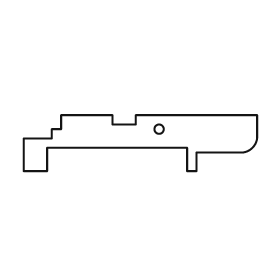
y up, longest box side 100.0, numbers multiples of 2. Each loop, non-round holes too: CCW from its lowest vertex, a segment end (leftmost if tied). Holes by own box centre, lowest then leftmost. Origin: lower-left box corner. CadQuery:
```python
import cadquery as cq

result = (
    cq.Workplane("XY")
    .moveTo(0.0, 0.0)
    .lineTo(10.0, 0.0)
    .lineTo(10.0, 10.0)
    .lineTo(70.0, 10.0)
    .lineTo(70.0, 0.0)
    .lineTo(74.0, 0.0)
    .lineTo(74.0, 8.0)
    .lineTo(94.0, 8.0)
    .threePointArc((98.0, 10.0), (100.0, 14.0))
    .lineTo(100.0, 24.0)
    .lineTo(48.0, 24.0)
    .lineTo(48.0, 20.0)
    .lineTo(38.0, 20.0)
    .lineTo(38.0, 24.0)
    .lineTo(16.0, 24.0)
    .lineTo(16.0, 18.0)
    .lineTo(12.0, 18.0)
    .lineTo(12.0, 14.0)
    .lineTo(0.0, 14.0)
    .close()
    .moveTo(58.0, 18.0)
    .circle(2.0)
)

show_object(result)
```